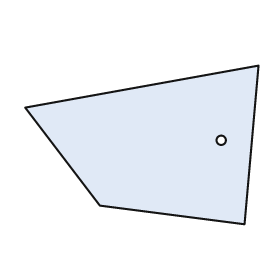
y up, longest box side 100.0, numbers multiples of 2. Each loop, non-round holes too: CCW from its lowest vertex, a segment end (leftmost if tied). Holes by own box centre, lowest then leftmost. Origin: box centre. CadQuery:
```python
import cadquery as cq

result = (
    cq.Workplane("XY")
    .moveTo(44.0, -34.0)
    .lineTo(50.0, 34.0)
    .lineTo(-50.0, 16.0)
    .lineTo(-18.0, -26.0)
    .close()
    .moveTo(34.0, 2.0)
    .circle(2.0)
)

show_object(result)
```